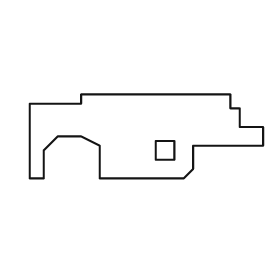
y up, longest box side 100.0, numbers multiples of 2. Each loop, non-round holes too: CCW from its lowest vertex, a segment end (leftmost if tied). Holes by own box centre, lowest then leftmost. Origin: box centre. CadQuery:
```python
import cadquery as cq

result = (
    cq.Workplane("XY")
    .moveTo(-50.0, -18.0)
    .lineTo(-44.0, -18.0)
    .lineTo(-44.0, -6.0)
    .lineTo(-38.0, 0.0)
    .lineTo(-28.0, 0.0)
    .lineTo(-20.0, -4.0)
    .lineTo(-20.0, -18.0)
    .lineTo(16.0, -18.0)
    .lineTo(20.0, -14.0)
    .lineTo(20.0, -4.0)
    .lineTo(50.0, -4.0)
    .lineTo(50.0, 4.0)
    .lineTo(40.0, 4.0)
    .lineTo(40.0, 12.0)
    .lineTo(36.0, 12.0)
    .lineTo(36.0, 18.0)
    .lineTo(-28.0, 18.0)
    .lineTo(-28.0, 14.0)
    .lineTo(-50.0, 14.0)
    .close()
    .moveTo(4.0, -10.0)
    .lineTo(12.0, -10.0)
    .lineTo(12.0, -2.0)
    .lineTo(4.0, -2.0)
    .close()
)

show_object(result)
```